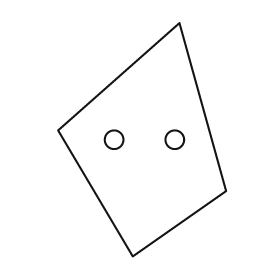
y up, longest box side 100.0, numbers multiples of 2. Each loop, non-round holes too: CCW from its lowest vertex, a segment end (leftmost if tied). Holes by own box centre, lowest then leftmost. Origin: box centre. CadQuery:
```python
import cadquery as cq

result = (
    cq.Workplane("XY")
    .moveTo(-4.0, -50.0)
    .lineTo(36.0, -22.0)
    .lineTo(16.0, 50.0)
    .lineTo(-36.0, 4.0)
    .close()
    .moveTo(-12.0, 0.0)
    .circle(4.0)
    .moveTo(14.0, 0.0)
    .circle(4.0)
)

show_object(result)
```